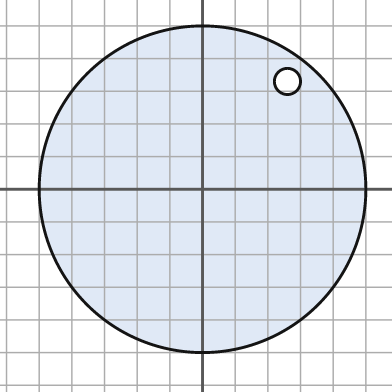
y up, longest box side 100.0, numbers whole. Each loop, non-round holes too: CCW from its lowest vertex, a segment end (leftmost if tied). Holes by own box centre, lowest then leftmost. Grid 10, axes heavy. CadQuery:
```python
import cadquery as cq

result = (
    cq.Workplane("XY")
    .moveTo(0.0, 0.0)
    .circle(50.0)
    .moveTo(26.0, 33.0)
    .circle(4.0)
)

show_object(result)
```